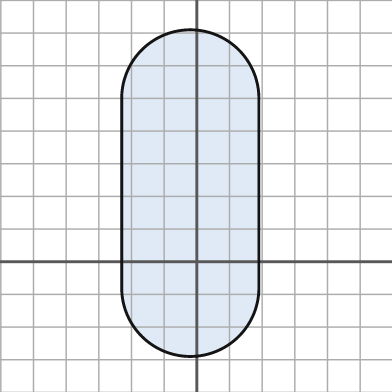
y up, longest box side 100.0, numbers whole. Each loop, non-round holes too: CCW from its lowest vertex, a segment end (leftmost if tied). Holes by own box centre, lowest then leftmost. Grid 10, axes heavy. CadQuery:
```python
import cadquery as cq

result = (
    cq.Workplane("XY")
    .moveTo(-23.0, -8.0)
    .threePointArc((-2.0, -29.0), (19.0, -8.0))
    .lineTo(19.0, 50.0)
    .threePointArc((-2.0, 71.0), (-23.0, 50.0))
    .close()
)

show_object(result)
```